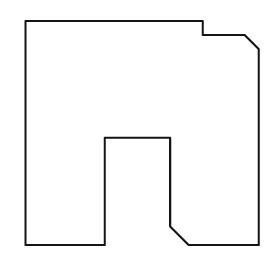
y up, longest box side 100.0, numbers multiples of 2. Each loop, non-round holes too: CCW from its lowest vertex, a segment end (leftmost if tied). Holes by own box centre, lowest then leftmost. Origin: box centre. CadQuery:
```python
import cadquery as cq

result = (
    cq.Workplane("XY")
    .moveTo(-50.0, -48.0)
    .lineTo(-16.0, -48.0)
    .lineTo(-16.0, -2.0)
    .lineTo(12.0, -2.0)
    .lineTo(12.0, -40.0)
    .lineTo(20.0, -48.0)
    .lineTo(50.0, -48.0)
    .lineTo(50.0, 36.0)
    .lineTo(44.0, 42.0)
    .lineTo(26.0, 42.0)
    .lineTo(26.0, 48.0)
    .lineTo(-50.0, 48.0)
    .close()
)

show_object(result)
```